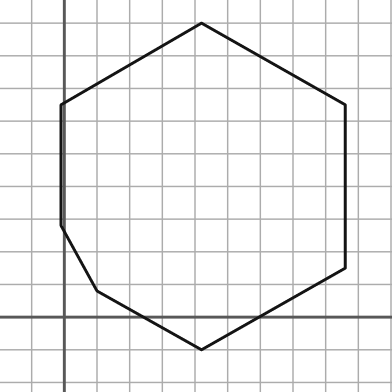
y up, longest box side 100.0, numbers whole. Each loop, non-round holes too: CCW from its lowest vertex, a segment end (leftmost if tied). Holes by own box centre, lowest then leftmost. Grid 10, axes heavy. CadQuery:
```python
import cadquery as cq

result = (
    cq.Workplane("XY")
    .moveTo(42.0, -10.0)
    .lineTo(86.0, 15.0)
    .lineTo(86.0, 65.0)
    .lineTo(42.0, 90.0)
    .lineTo(-1.0, 65.0)
    .lineTo(-1.0, 28.0)
    .lineTo(10.0, 8.0)
    .close()
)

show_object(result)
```